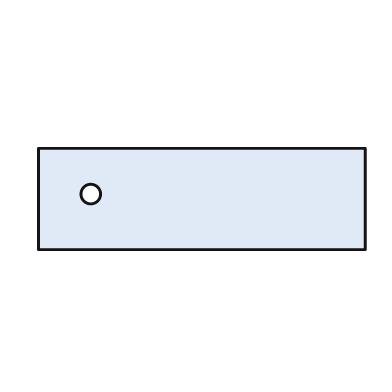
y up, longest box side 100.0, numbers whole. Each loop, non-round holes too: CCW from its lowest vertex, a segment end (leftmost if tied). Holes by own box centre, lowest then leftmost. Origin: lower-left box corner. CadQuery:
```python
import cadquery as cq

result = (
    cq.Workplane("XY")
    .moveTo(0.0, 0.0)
    .lineTo(100.0, 0.0)
    .lineTo(100.0, 31.0)
    .lineTo(0.0, 31.0)
    .close()
    .moveTo(16.0, 17.0)
    .circle(3.0)
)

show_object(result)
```